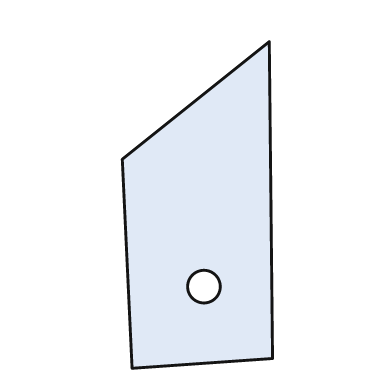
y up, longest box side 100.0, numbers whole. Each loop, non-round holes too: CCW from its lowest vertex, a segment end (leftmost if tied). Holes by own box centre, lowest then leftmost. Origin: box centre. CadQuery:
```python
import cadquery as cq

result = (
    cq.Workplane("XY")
    .moveTo(-20.0, -50.0)
    .lineTo(23.0, -47.0)
    .lineTo(22.0, 50.0)
    .lineTo(-23.0, 14.0)
    .close()
    .moveTo(2.0, -25.0)
    .circle(5.0)
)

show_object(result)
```